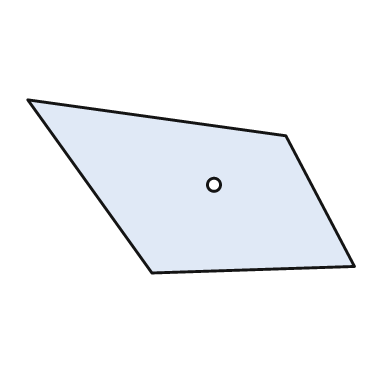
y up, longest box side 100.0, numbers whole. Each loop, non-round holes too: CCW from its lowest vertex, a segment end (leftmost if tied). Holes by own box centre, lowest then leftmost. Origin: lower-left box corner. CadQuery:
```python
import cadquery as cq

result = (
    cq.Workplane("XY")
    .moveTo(38.0, 0.0)
    .lineTo(100.0, 2.0)
    .lineTo(79.0, 42.0)
    .lineTo(0.0, 53.0)
    .close()
    .moveTo(57.0, 27.0)
    .circle(2.0)
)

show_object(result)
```